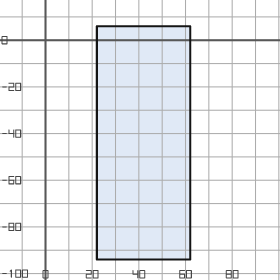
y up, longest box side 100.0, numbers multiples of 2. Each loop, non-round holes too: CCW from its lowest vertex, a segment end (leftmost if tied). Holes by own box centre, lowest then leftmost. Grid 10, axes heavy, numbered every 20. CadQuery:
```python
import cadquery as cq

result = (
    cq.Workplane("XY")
    .moveTo(22.0, -94.0)
    .lineTo(62.0, -94.0)
    .lineTo(62.0, 6.0)
    .lineTo(22.0, 6.0)
    .close()
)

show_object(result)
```